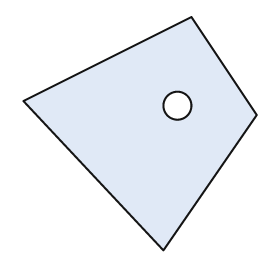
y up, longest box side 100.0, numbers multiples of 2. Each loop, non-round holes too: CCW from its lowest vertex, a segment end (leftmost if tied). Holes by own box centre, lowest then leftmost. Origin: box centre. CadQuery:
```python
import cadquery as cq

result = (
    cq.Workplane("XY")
    .moveTo(10.0, -50.0)
    .lineTo(50.0, 8.0)
    .lineTo(22.0, 50.0)
    .lineTo(-50.0, 14.0)
    .close()
    .moveTo(16.0, 12.0)
    .circle(6.0)
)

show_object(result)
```